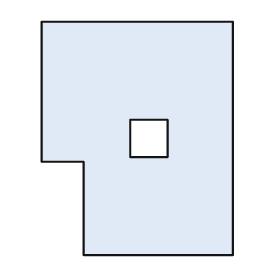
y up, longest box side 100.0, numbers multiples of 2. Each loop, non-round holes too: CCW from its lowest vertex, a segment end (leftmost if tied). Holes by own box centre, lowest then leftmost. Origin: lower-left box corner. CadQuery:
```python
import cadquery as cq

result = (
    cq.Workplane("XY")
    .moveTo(18.0, 0.0)
    .lineTo(82.0, 0.0)
    .lineTo(82.0, 100.0)
    .lineTo(0.0, 100.0)
    .lineTo(0.0, 40.0)
    .lineTo(18.0, 40.0)
    .close()
    .moveTo(38.0, 42.0)
    .lineTo(54.0, 42.0)
    .lineTo(54.0, 58.0)
    .lineTo(38.0, 58.0)
    .close()
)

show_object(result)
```